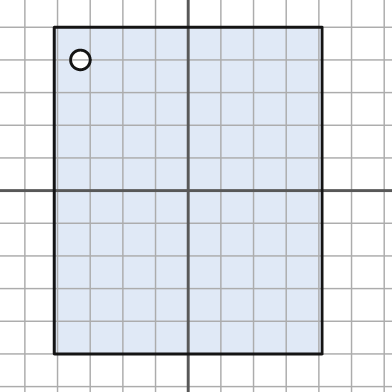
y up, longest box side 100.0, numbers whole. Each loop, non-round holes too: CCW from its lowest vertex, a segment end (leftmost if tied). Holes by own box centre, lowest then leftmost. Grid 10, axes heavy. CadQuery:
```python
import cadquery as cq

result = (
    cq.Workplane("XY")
    .moveTo(-41.0, -50.0)
    .lineTo(41.0, -50.0)
    .lineTo(41.0, 50.0)
    .lineTo(-41.0, 50.0)
    .close()
    .moveTo(-33.0, 40.0)
    .circle(3.0)
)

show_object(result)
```